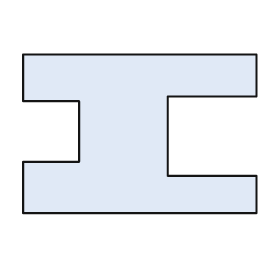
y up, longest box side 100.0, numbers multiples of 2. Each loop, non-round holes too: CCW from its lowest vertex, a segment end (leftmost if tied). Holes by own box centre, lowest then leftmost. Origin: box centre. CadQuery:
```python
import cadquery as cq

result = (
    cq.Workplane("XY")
    .moveTo(-50.0, -34.0)
    .lineTo(50.0, -34.0)
    .lineTo(50.0, -18.0)
    .lineTo(12.0, -18.0)
    .lineTo(12.0, 16.0)
    .lineTo(50.0, 16.0)
    .lineTo(50.0, 34.0)
    .lineTo(-50.0, 34.0)
    .lineTo(-50.0, 14.0)
    .lineTo(-26.0, 14.0)
    .lineTo(-26.0, -12.0)
    .lineTo(-50.0, -12.0)
    .close()
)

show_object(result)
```